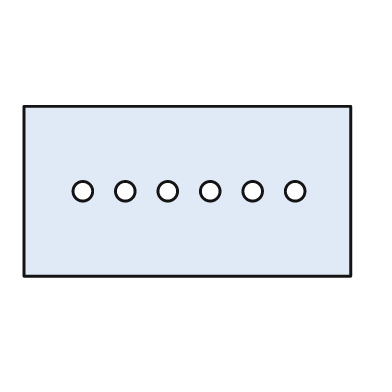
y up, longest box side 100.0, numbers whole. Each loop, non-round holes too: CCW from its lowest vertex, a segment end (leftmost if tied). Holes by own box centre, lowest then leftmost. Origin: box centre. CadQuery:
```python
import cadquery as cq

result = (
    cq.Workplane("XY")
    .moveTo(-50.0, -26.0)
    .lineTo(50.0, -26.0)
    .lineTo(50.0, 26.0)
    .lineTo(-50.0, 26.0)
    .close()
    .moveTo(-32.0, 0.0)
    .circle(3.0)
    .moveTo(-19.0, 0.0)
    .circle(3.0)
    .moveTo(-6.0, 0.0)
    .circle(3.0)
    .moveTo(7.0, 0.0)
    .circle(3.0)
    .moveTo(20.0, 0.0)
    .circle(3.0)
    .moveTo(33.0, 0.0)
    .circle(3.0)
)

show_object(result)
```